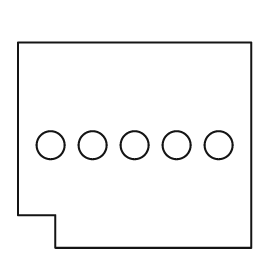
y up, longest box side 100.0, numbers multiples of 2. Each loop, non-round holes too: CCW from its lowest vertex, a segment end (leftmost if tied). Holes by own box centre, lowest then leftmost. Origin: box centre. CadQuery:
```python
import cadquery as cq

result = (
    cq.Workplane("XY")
    .moveTo(-34.0, -44.0)
    .lineTo(50.0, -44.0)
    .lineTo(50.0, 44.0)
    .lineTo(-50.0, 44.0)
    .lineTo(-50.0, -30.0)
    .lineTo(-34.0, -30.0)
    .close()
    .moveTo(-36.0, 0.0)
    .circle(6.0)
    .moveTo(-18.0, 0.0)
    .circle(6.0)
    .moveTo(0.0, 0.0)
    .circle(6.0)
    .moveTo(18.0, 0.0)
    .circle(6.0)
    .moveTo(36.0, 0.0)
    .circle(6.0)
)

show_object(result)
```